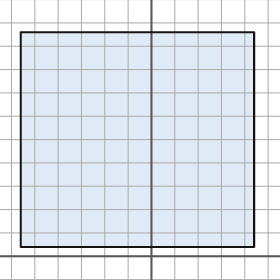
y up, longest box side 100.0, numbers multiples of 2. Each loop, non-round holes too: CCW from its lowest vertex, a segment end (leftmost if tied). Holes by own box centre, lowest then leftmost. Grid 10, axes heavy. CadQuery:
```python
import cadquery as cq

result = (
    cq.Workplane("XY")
    .moveTo(-56.0, 4.0)
    .lineTo(44.0, 4.0)
    .lineTo(44.0, 96.0)
    .lineTo(-56.0, 96.0)
    .close()
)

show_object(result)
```